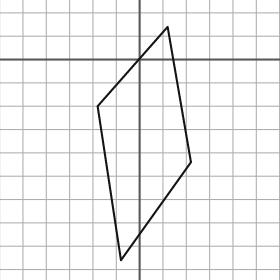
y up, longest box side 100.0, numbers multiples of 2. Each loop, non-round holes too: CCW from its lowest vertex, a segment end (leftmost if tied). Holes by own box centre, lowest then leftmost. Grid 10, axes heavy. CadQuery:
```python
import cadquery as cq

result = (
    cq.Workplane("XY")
    .moveTo(-8.0, -86.0)
    .lineTo(22.0, -44.0)
    .lineTo(12.0, 14.0)
    .lineTo(-18.0, -20.0)
    .close()
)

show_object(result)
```